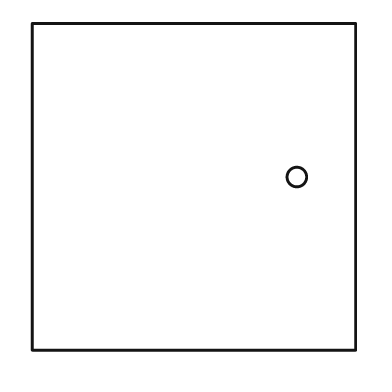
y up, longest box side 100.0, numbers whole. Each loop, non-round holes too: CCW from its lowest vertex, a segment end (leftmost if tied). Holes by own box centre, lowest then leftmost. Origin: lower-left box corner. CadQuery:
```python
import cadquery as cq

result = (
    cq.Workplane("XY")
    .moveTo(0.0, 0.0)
    .lineTo(99.0, 0.0)
    .lineTo(99.0, 100.0)
    .lineTo(0.0, 100.0)
    .close()
    .moveTo(81.0, 53.0)
    .circle(3.0)
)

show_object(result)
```